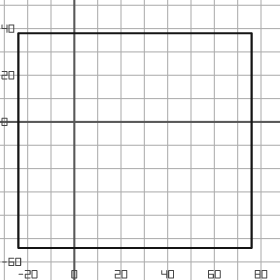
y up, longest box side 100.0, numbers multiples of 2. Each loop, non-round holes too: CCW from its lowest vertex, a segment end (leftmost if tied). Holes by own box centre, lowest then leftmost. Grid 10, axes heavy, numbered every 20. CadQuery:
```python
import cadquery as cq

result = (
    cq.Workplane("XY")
    .moveTo(-24.0, -54.0)
    .lineTo(76.0, -54.0)
    .lineTo(76.0, 38.0)
    .lineTo(-24.0, 38.0)
    .close()
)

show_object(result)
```